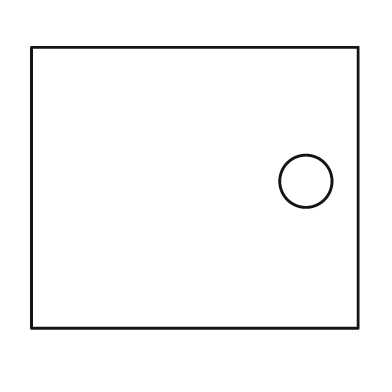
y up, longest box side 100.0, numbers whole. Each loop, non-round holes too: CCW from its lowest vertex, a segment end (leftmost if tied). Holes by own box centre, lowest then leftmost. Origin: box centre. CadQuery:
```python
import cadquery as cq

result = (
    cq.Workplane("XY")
    .moveTo(-50.0, -43.0)
    .lineTo(50.0, -43.0)
    .lineTo(50.0, 43.0)
    .lineTo(-50.0, 43.0)
    .close()
    .moveTo(34.0, 2.0)
    .circle(8.0)
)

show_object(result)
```